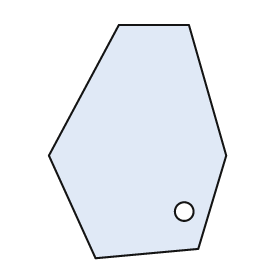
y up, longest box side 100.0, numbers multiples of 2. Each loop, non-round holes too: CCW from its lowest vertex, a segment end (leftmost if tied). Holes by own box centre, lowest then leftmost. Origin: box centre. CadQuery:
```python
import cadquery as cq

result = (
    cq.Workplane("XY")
    .moveTo(-18.0, -50.0)
    .lineTo(26.0, -46.0)
    .lineTo(38.0, -6.0)
    .lineTo(22.0, 50.0)
    .lineTo(-8.0, 50.0)
    .lineTo(-38.0, -6.0)
    .close()
    .moveTo(20.0, -30.0)
    .circle(4.0)
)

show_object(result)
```